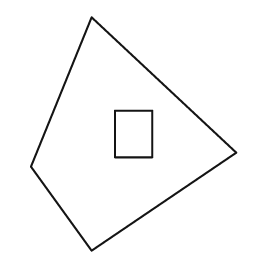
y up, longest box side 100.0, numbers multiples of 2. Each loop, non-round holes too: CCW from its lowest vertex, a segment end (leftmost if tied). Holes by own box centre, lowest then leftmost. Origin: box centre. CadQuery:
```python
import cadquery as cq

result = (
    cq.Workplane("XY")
    .moveTo(-18.0, -50.0)
    .lineTo(44.0, -8.0)
    .lineTo(-18.0, 50.0)
    .lineTo(-44.0, -14.0)
    .close()
    .moveTo(-8.0, -10.0)
    .lineTo(8.0, -10.0)
    .lineTo(8.0, 10.0)
    .lineTo(-8.0, 10.0)
    .close()
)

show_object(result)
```